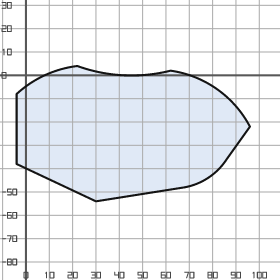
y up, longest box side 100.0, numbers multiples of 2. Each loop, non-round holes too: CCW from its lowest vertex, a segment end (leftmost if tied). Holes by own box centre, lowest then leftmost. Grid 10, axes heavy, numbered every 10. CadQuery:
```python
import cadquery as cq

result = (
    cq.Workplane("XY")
    .moveTo(30.0, -54.0)
    .lineTo(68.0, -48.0)
    .threePointArc((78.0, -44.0), (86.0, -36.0))
    .lineTo(96.0, -22.0)
    .threePointArc((82.0, -6.0), (62.0, 2.0))
    .threePointArc((42.0, 0.0), (22.0, 4.0))
    .threePointArc((8.0, 0.0), (-4.0, -8.0))
    .lineTo(-4.0, -38.0)
    .close()
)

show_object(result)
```